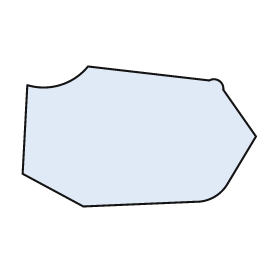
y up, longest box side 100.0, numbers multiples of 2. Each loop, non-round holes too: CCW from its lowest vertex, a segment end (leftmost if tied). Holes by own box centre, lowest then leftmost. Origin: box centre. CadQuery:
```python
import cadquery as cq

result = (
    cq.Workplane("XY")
    .moveTo(-24.0, -30.0)
    .lineTo(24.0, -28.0)
    .threePointArc((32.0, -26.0), (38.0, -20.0))
    .lineTo(50.0, 0.0)
    .lineTo(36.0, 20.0)
    .threePointArc((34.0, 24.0), (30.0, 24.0))
    .lineTo(-22.0, 30.0)
    .threePointArc((-34.0, 22.0), (-48.0, 22.0))
    .lineTo(-50.0, -16.0)
    .close()
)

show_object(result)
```